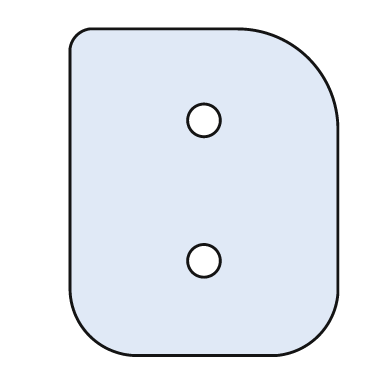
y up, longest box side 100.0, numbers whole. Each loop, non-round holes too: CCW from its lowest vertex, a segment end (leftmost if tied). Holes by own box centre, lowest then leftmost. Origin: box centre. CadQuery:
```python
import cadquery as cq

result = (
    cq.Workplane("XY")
    .moveTo(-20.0, -50.0)
    .lineTo(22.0, -50.0)
    .threePointArc((35.0, -44.0), (41.0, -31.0))
    .lineTo(41.0, 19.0)
    .threePointArc((32.0, 41.0), (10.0, 50.0))
    .lineTo(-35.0, 50.0)
    .threePointArc((-39.0, 48.0), (-41.0, 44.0))
    .lineTo(-41.0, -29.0)
    .threePointArc((-35.0, -44.0), (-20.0, -50.0))
    .close()
    .moveTo(0.0, -21.0)
    .circle(5.0)
    .moveTo(0.0, 22.0)
    .circle(5.0)
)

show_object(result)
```